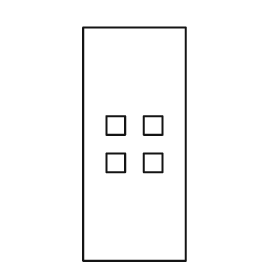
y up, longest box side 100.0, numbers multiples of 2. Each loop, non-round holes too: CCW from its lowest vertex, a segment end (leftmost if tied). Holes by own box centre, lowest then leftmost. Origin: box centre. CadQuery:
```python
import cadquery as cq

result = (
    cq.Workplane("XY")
    .moveTo(-22.0, -50.0)
    .lineTo(22.0, -50.0)
    .lineTo(22.0, 50.0)
    .lineTo(-22.0, 50.0)
    .close()
    .moveTo(-12.0, -12.0)
    .lineTo(-4.0, -12.0)
    .lineTo(-4.0, -4.0)
    .lineTo(-12.0, -4.0)
    .close()
    .moveTo(4.0, -12.0)
    .lineTo(12.0, -12.0)
    .lineTo(12.0, -4.0)
    .lineTo(4.0, -4.0)
    .close()
    .moveTo(-12.0, 4.0)
    .lineTo(-4.0, 4.0)
    .lineTo(-4.0, 12.0)
    .lineTo(-12.0, 12.0)
    .close()
    .moveTo(4.0, 4.0)
    .lineTo(12.0, 4.0)
    .lineTo(12.0, 12.0)
    .lineTo(4.0, 12.0)
    .close()
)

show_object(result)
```